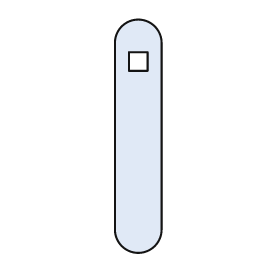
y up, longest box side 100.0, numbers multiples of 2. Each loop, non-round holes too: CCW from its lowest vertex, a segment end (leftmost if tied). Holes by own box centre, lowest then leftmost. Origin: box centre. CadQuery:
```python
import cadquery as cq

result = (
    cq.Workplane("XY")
    .moveTo(-10.0, -40.0)
    .threePointArc((0.0, -50.0), (10.0, -40.0))
    .lineTo(10.0, 40.0)
    .threePointArc((0.0, 50.0), (-10.0, 40.0))
    .close()
    .moveTo(-4.0, 28.0)
    .lineTo(4.0, 28.0)
    .lineTo(4.0, 36.0)
    .lineTo(-4.0, 36.0)
    .close()
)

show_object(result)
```